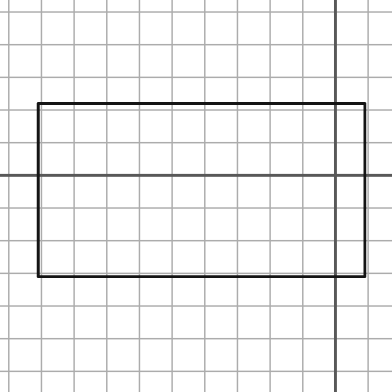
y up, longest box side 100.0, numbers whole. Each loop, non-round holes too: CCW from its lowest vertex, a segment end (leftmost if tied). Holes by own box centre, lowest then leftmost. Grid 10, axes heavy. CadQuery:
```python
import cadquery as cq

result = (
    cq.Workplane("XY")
    .moveTo(-91.0, -31.0)
    .lineTo(9.0, -31.0)
    .lineTo(9.0, 22.0)
    .lineTo(-91.0, 22.0)
    .close()
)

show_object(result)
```